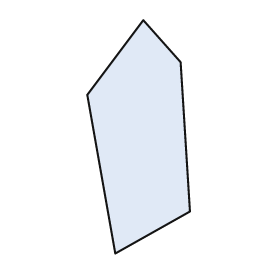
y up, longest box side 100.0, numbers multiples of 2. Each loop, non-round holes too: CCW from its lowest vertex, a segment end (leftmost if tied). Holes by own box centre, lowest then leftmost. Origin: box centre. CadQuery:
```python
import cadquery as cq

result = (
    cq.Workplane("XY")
    .moveTo(-10.0, -50.0)
    .lineTo(22.0, -32.0)
    .lineTo(18.0, 32.0)
    .lineTo(2.0, 50.0)
    .lineTo(-22.0, 18.0)
    .close()
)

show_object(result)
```